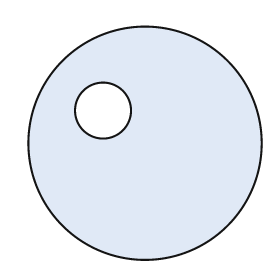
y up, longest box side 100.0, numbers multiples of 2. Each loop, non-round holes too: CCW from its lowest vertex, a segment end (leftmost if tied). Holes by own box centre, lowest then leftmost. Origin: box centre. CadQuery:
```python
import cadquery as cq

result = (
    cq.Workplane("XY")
    .moveTo(0.0, 0.0)
    .circle(50.0)
    .moveTo(-18.0, 14.0)
    .circle(12.0)
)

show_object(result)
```